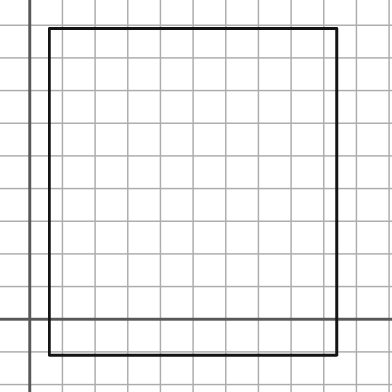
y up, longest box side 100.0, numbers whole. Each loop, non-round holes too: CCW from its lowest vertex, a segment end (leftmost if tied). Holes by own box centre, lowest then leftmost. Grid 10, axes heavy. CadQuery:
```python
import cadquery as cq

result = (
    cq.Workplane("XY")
    .moveTo(6.0, -11.0)
    .lineTo(94.0, -11.0)
    .lineTo(94.0, 89.0)
    .lineTo(6.0, 89.0)
    .close()
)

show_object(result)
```